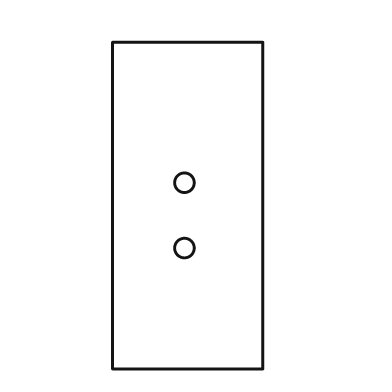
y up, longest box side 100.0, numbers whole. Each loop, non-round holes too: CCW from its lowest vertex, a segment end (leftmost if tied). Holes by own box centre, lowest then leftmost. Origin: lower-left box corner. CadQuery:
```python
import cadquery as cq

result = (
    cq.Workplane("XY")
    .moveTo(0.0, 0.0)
    .lineTo(46.0, 0.0)
    .lineTo(46.0, 100.0)
    .lineTo(0.0, 100.0)
    .close()
    .moveTo(22.0, 37.0)
    .circle(3.0)
    .moveTo(22.0, 57.0)
    .circle(3.0)
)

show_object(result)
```